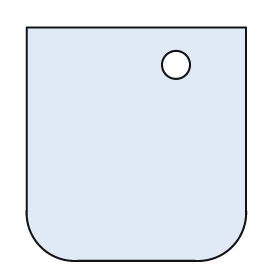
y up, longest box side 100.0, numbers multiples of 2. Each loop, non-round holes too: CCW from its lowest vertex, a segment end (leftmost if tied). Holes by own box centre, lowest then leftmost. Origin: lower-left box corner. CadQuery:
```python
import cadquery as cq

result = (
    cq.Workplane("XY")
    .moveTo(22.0, 0.0)
    .lineTo(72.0, 0.0)
    .threePointArc((88.0, 6.0), (94.0, 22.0))
    .lineTo(94.0, 100.0)
    .lineTo(0.0, 100.0)
    .lineTo(0.0, 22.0)
    .threePointArc((6.0, 6.0), (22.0, 0.0))
    .close()
    .moveTo(64.0, 84.0)
    .circle(6.0)
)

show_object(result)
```